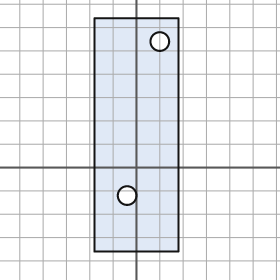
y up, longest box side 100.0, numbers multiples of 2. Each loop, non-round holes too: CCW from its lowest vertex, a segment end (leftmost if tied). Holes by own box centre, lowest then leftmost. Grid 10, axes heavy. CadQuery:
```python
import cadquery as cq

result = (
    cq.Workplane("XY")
    .moveTo(-18.0, -36.0)
    .lineTo(18.0, -36.0)
    .lineTo(18.0, 64.0)
    .lineTo(-18.0, 64.0)
    .close()
    .moveTo(-4.0, -12.0)
    .circle(4.0)
    .moveTo(10.0, 54.0)
    .circle(4.0)
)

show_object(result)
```